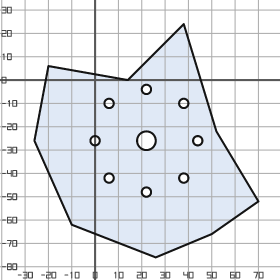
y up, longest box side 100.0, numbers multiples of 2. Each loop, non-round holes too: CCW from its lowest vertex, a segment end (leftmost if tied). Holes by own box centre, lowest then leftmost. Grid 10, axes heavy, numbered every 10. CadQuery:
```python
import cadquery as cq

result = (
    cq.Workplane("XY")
    .moveTo(26.0, -76.0)
    .lineTo(50.0, -66.0)
    .lineTo(70.0, -52.0)
    .lineTo(52.0, -22.0)
    .lineTo(38.0, 24.0)
    .lineTo(14.0, 0.0)
    .lineTo(-20.0, 6.0)
    .lineTo(-26.0, -26.0)
    .lineTo(-10.0, -62.0)
    .close()
    .moveTo(22.0, -48.0)
    .circle(2.0)
    .moveTo(6.0, -42.0)
    .circle(2.0)
    .moveTo(38.0, -42.0)
    .circle(2.0)
    .moveTo(0.0, -26.0)
    .circle(2.0)
    .moveTo(22.0, -26.0)
    .circle(4.0)
    .moveTo(44.0, -26.0)
    .circle(2.0)
    .moveTo(6.0, -10.0)
    .circle(2.0)
    .moveTo(38.0, -10.0)
    .circle(2.0)
    .moveTo(22.0, -4.0)
    .circle(2.0)
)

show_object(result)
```